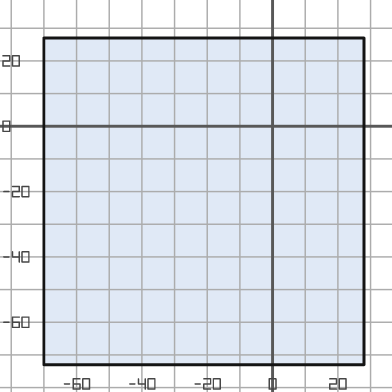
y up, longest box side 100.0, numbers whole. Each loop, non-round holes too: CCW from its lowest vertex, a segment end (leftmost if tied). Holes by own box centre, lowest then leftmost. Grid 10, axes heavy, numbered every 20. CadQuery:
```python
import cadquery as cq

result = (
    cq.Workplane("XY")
    .moveTo(-70.0, -73.0)
    .lineTo(28.0, -73.0)
    .lineTo(28.0, 27.0)
    .lineTo(-70.0, 27.0)
    .close()
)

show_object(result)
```